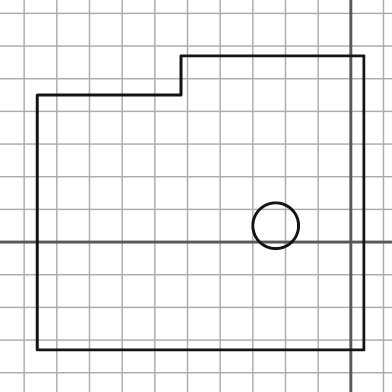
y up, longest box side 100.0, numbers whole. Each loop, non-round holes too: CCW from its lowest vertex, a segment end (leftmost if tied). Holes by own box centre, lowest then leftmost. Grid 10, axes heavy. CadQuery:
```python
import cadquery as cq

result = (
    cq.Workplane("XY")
    .moveTo(-96.0, -33.0)
    .lineTo(4.0, -33.0)
    .lineTo(4.0, 57.0)
    .lineTo(-52.0, 57.0)
    .lineTo(-52.0, 45.0)
    .lineTo(-96.0, 45.0)
    .close()
    .moveTo(-23.0, 5.0)
    .circle(7.0)
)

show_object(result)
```